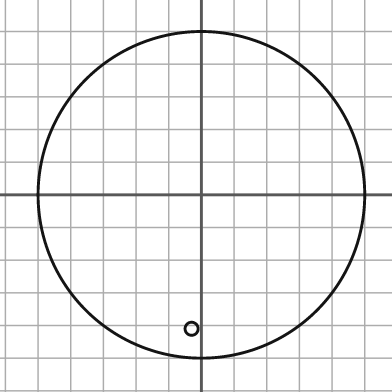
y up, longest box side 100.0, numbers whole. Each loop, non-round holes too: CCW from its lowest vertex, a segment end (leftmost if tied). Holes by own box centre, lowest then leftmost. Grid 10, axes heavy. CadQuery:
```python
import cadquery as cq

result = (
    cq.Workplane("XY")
    .moveTo(0.0, 0.0)
    .circle(50.0)
    .moveTo(-3.0, -41.0)
    .circle(2.0)
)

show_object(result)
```